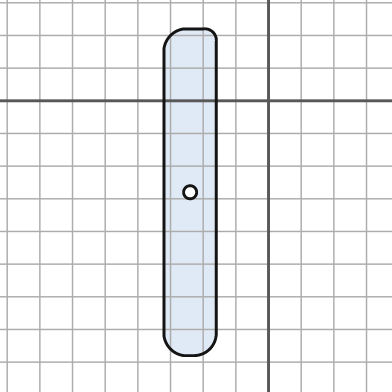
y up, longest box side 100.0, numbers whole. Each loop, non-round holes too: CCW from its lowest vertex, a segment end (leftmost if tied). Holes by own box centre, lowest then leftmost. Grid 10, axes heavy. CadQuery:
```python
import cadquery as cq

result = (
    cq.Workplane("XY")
    .moveTo(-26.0, -78.0)
    .lineTo(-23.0, -78.0)
    .threePointArc((-18.0, -76.0), (-16.0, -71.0))
    .lineTo(-16.0, 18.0)
    .threePointArc((-17.0, 21.0), (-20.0, 22.0))
    .lineTo(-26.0, 22.0)
    .threePointArc((-30.0, 20.0), (-32.0, 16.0))
    .lineTo(-32.0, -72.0)
    .threePointArc((-30.0, -76.0), (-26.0, -78.0))
    .close()
    .moveTo(-24.0, -28.0)
    .circle(2.0)
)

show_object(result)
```